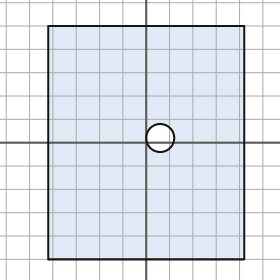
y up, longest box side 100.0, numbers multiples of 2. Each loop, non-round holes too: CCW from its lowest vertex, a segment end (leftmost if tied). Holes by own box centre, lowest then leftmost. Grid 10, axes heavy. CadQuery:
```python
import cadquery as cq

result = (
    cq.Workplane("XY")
    .moveTo(-42.0, -50.0)
    .lineTo(42.0, -50.0)
    .lineTo(42.0, 50.0)
    .lineTo(-42.0, 50.0)
    .close()
    .moveTo(6.0, 2.0)
    .circle(6.0)
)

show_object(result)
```